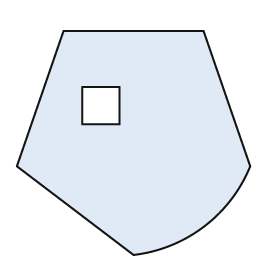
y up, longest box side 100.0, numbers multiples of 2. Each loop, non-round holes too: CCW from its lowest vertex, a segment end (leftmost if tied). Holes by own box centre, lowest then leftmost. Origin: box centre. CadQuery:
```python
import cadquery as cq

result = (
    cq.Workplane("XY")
    .moveTo(0.0, -48.0)
    .threePointArc((30.0, -36.0), (50.0, -10.0))
    .lineTo(30.0, 48.0)
    .lineTo(-30.0, 48.0)
    .lineTo(-50.0, -10.0)
    .close()
    .moveTo(-22.0, 8.0)
    .lineTo(-6.0, 8.0)
    .lineTo(-6.0, 24.0)
    .lineTo(-22.0, 24.0)
    .close()
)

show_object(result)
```